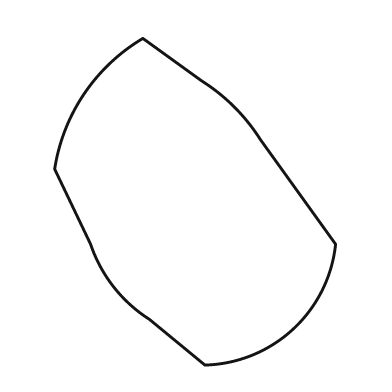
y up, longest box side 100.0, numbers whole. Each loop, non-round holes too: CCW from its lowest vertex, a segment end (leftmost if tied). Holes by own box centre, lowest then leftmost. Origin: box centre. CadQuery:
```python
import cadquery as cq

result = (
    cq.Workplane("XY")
    .moveTo(3.0, -50.0)
    .threePointArc((30.0, -39.0), (43.0, -13.0))
    .lineTo(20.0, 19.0)
    .threePointArc((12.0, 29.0), (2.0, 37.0))
    .lineTo(-16.0, 50.0)
    .threePointArc((-34.0, 33.0), (-43.0, 10.0))
    .lineTo(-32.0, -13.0)
    .threePointArc((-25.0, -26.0), (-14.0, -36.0))
    .close()
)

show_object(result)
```